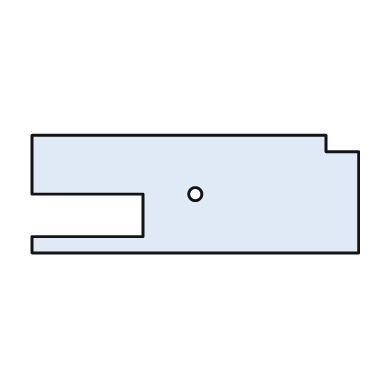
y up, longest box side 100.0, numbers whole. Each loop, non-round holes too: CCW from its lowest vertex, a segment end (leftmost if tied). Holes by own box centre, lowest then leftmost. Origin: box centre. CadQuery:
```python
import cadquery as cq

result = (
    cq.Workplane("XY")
    .moveTo(-50.0, -18.0)
    .lineTo(50.0, -18.0)
    .lineTo(50.0, 13.0)
    .lineTo(40.0, 13.0)
    .lineTo(40.0, 18.0)
    .lineTo(-50.0, 18.0)
    .lineTo(-50.0, 0.0)
    .lineTo(-16.0, 0.0)
    .lineTo(-16.0, -13.0)
    .lineTo(-50.0, -13.0)
    .close()
    .moveTo(0.0, 0.0)
    .circle(2.0)
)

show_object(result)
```